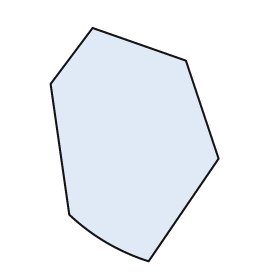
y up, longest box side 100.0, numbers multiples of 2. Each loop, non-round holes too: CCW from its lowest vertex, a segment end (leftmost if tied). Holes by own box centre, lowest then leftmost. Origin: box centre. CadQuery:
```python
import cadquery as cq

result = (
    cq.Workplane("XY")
    .moveTo(6.0, -50.0)
    .lineTo(36.0, -6.0)
    .lineTo(22.0, 36.0)
    .lineTo(-18.0, 50.0)
    .lineTo(-36.0, 26.0)
    .lineTo(-28.0, -30.0)
    .threePointArc((-12.0, -42.0), (6.0, -50.0))
    .close()
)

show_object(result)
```